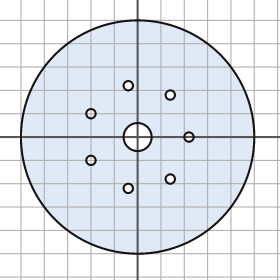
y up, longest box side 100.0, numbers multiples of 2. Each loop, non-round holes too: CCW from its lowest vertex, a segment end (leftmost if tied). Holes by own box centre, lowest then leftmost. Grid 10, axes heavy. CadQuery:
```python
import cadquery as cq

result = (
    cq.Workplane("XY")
    .moveTo(0.0, 0.0)
    .circle(50.0)
    .moveTo(-4.0, -22.0)
    .circle(2.0)
    .moveTo(14.0, -18.0)
    .circle(2.0)
    .moveTo(-20.0, -10.0)
    .circle(2.0)
    .moveTo(0.0, 0.0)
    .circle(6.0)
    .moveTo(22.0, 0.0)
    .circle(2.0)
    .moveTo(-20.0, 10.0)
    .circle(2.0)
    .moveTo(14.0, 18.0)
    .circle(2.0)
    .moveTo(-4.0, 22.0)
    .circle(2.0)
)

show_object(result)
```